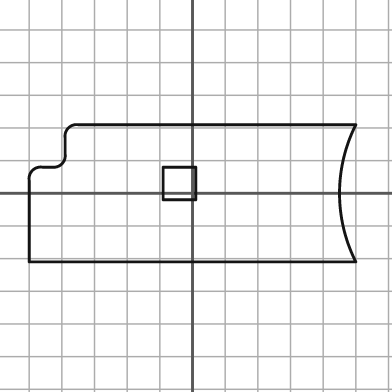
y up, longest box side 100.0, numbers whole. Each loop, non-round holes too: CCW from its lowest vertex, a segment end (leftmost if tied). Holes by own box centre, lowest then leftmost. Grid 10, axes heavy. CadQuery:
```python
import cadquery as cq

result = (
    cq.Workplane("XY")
    .moveTo(-50.0, -21.0)
    .lineTo(50.0, -21.0)
    .threePointArc((45.0, 0.0), (50.0, 21.0))
    .lineTo(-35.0, 21.0)
    .threePointArc((-38.0, 20.0), (-39.0, 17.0))
    .lineTo(-39.0, 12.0)
    .threePointArc((-40.0, 9.0), (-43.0, 8.0))
    .lineTo(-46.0, 8.0)
    .threePointArc((-49.0, 7.0), (-50.0, 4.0))
    .close()
    .moveTo(-9.0, -2.0)
    .lineTo(1.0, -2.0)
    .lineTo(1.0, 8.0)
    .lineTo(-9.0, 8.0)
    .close()
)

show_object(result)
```